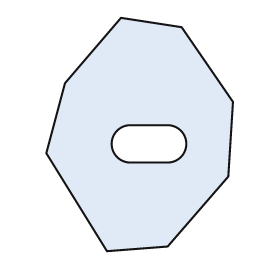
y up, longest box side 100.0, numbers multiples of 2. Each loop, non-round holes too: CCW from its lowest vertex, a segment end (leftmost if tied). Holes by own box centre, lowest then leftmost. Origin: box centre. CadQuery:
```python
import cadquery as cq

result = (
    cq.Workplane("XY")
    .moveTo(-14.0, -50.0)
    .lineTo(12.0, -48.0)
    .lineTo(38.0, -18.0)
    .lineTo(40.0, 14.0)
    .lineTo(18.0, 46.0)
    .lineTo(-8.0, 50.0)
    .lineTo(-32.0, 22.0)
    .lineTo(-40.0, -8.0)
    .close()
    .moveTo(-4.0, -12.0)
    .lineTo(12.0, -12.0)
    .threePointArc((20.0, -4.0), (12.0, 4.0))
    .lineTo(-4.0, 4.0)
    .threePointArc((-12.0, -4.0), (-4.0, -12.0))
    .close()
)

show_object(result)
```